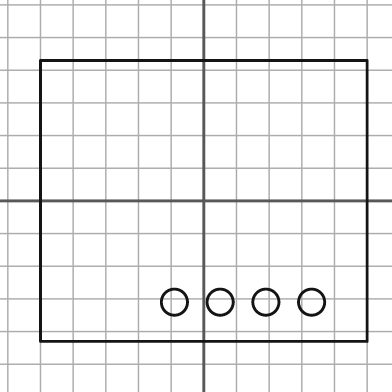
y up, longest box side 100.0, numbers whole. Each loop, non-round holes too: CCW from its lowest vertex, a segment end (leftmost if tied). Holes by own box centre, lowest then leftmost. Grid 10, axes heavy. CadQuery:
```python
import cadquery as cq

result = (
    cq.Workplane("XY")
    .moveTo(-50.0, -43.0)
    .lineTo(50.0, -43.0)
    .lineTo(50.0, 43.0)
    .lineTo(-50.0, 43.0)
    .close()
    .moveTo(-9.0, -31.0)
    .circle(4.0)
    .moveTo(5.0, -31.0)
    .circle(4.0)
    .moveTo(19.0, -31.0)
    .circle(4.0)
    .moveTo(33.0, -31.0)
    .circle(4.0)
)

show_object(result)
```